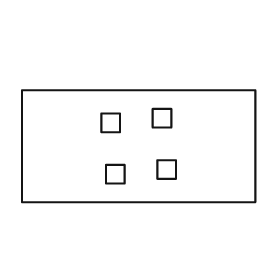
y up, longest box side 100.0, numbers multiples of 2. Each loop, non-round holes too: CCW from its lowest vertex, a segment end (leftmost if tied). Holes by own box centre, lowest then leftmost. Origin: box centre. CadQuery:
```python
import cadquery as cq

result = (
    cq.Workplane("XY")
    .moveTo(-50.0, -24.0)
    .lineTo(50.0, -24.0)
    .lineTo(50.0, 24.0)
    .lineTo(-50.0, 24.0)
    .close()
    .moveTo(-14.0, -16.0)
    .lineTo(-6.0, -16.0)
    .lineTo(-6.0, -8.0)
    .lineTo(-14.0, -8.0)
    .close()
    .moveTo(8.0, -14.0)
    .lineTo(16.0, -14.0)
    .lineTo(16.0, -6.0)
    .lineTo(8.0, -6.0)
    .close()
    .moveTo(-16.0, 6.0)
    .lineTo(-8.0, 6.0)
    .lineTo(-8.0, 14.0)
    .lineTo(-16.0, 14.0)
    .close()
    .moveTo(6.0, 8.0)
    .lineTo(14.0, 8.0)
    .lineTo(14.0, 16.0)
    .lineTo(6.0, 16.0)
    .close()
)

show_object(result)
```